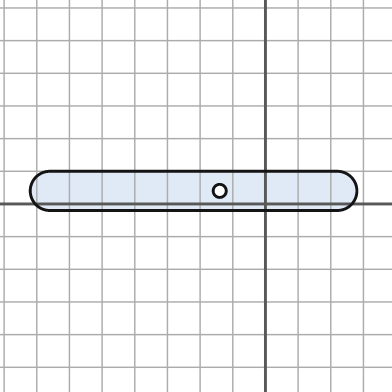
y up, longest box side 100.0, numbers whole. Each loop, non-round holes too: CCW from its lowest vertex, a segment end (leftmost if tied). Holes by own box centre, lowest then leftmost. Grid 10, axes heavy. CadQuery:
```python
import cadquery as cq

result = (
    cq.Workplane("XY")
    .moveTo(-66.0, -2.0)
    .lineTo(22.0, -2.0)
    .threePointArc((28.0, 4.0), (22.0, 10.0))
    .lineTo(-66.0, 10.0)
    .threePointArc((-72.0, 4.0), (-66.0, -2.0))
    .close()
    .moveTo(-14.0, 4.0)
    .circle(2.0)
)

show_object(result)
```